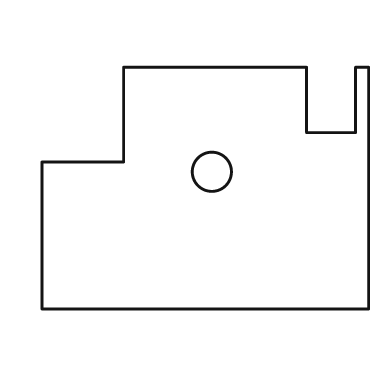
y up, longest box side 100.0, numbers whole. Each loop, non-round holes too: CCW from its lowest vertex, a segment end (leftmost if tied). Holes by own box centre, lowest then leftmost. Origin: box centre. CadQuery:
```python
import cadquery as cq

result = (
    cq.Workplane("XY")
    .moveTo(-50.0, -37.0)
    .lineTo(50.0, -37.0)
    .lineTo(50.0, 37.0)
    .lineTo(46.0, 37.0)
    .lineTo(46.0, 17.0)
    .lineTo(31.0, 17.0)
    .lineTo(31.0, 37.0)
    .lineTo(-25.0, 37.0)
    .lineTo(-25.0, 8.0)
    .lineTo(-50.0, 8.0)
    .close()
    .moveTo(2.0, 5.0)
    .circle(6.0)
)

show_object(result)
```